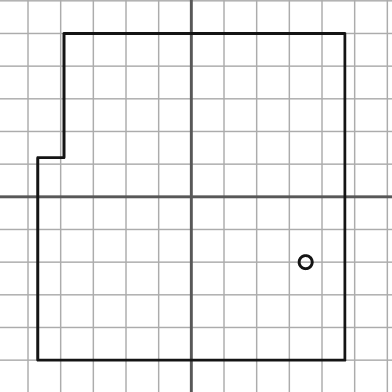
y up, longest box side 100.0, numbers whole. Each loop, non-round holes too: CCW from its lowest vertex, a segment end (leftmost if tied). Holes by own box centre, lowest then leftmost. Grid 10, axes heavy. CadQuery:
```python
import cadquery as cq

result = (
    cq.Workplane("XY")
    .moveTo(-47.0, -50.0)
    .lineTo(47.0, -50.0)
    .lineTo(47.0, 50.0)
    .lineTo(-39.0, 50.0)
    .lineTo(-39.0, 12.0)
    .lineTo(-47.0, 12.0)
    .close()
    .moveTo(35.0, -20.0)
    .circle(2.0)
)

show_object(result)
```